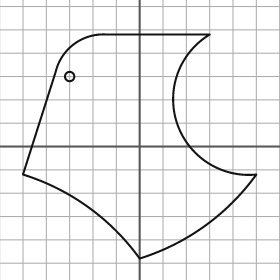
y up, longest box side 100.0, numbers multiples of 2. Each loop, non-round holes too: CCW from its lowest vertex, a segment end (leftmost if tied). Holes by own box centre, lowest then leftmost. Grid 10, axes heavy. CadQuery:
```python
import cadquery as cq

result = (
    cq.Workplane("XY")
    .moveTo(0.0, -48.0)
    .threePointArc((28.0, -34.0), (50.0, -12.0))
    .threePointArc((16.0, 10.0), (30.0, 48.0))
    .lineTo(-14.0, 48.0)
    .threePointArc((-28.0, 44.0), (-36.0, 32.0))
    .lineTo(-50.0, -12.0)
    .threePointArc((-22.0, -26.0), (0.0, -48.0))
    .close()
    .moveTo(-30.0, 30.0)
    .circle(2.0)
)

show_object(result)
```